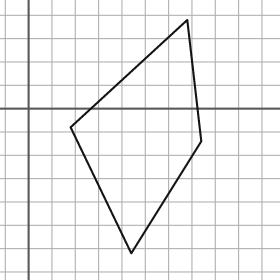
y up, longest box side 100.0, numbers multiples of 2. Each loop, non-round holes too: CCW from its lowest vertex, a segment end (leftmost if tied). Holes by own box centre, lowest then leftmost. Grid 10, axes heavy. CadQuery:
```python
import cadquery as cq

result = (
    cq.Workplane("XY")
    .moveTo(44.0, -62.0)
    .lineTo(74.0, -14.0)
    .lineTo(68.0, 38.0)
    .lineTo(18.0, -8.0)
    .close()
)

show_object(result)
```